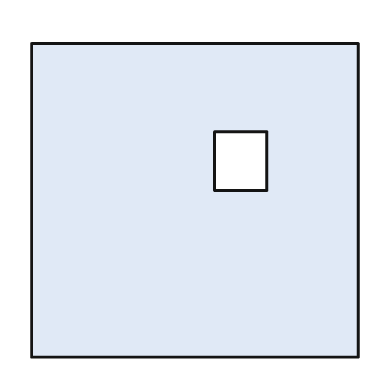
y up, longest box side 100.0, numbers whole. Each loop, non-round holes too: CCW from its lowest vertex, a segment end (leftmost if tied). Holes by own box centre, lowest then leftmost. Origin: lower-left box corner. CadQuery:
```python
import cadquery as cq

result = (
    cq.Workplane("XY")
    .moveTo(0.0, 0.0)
    .lineTo(100.0, 0.0)
    .lineTo(100.0, 96.0)
    .lineTo(0.0, 96.0)
    .close()
    .moveTo(56.0, 51.0)
    .lineTo(72.0, 51.0)
    .lineTo(72.0, 69.0)
    .lineTo(56.0, 69.0)
    .close()
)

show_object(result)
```